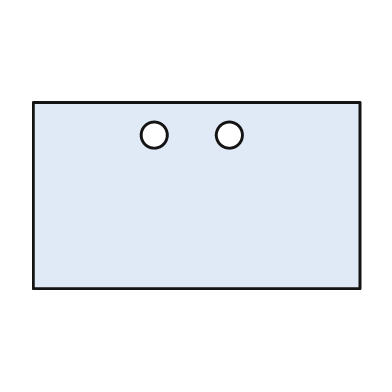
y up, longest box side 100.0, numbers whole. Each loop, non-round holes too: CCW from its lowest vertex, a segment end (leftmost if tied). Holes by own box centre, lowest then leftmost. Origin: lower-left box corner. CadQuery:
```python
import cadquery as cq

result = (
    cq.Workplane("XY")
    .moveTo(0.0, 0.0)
    .lineTo(100.0, 0.0)
    .lineTo(100.0, 57.0)
    .lineTo(0.0, 57.0)
    .close()
    .moveTo(37.0, 47.0)
    .circle(4.0)
    .moveTo(60.0, 47.0)
    .circle(4.0)
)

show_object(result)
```